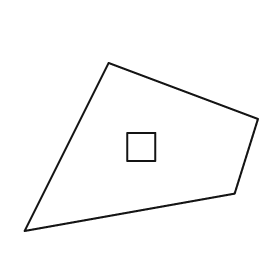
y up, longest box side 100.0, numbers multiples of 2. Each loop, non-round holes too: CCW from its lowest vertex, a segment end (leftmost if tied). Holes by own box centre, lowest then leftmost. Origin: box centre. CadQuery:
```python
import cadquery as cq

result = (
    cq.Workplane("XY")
    .moveTo(-50.0, -36.0)
    .lineTo(40.0, -20.0)
    .lineTo(50.0, 12.0)
    .lineTo(-14.0, 36.0)
    .close()
    .moveTo(-6.0, -6.0)
    .lineTo(6.0, -6.0)
    .lineTo(6.0, 6.0)
    .lineTo(-6.0, 6.0)
    .close()
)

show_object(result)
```